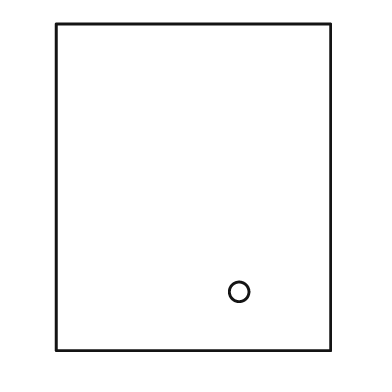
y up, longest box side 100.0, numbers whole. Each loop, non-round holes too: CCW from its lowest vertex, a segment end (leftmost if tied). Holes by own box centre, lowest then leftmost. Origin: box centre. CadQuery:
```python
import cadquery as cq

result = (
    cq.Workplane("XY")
    .moveTo(-42.0, -50.0)
    .lineTo(42.0, -50.0)
    .lineTo(42.0, 50.0)
    .lineTo(-42.0, 50.0)
    .close()
    .moveTo(14.0, -32.0)
    .circle(3.0)
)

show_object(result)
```